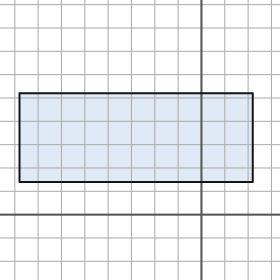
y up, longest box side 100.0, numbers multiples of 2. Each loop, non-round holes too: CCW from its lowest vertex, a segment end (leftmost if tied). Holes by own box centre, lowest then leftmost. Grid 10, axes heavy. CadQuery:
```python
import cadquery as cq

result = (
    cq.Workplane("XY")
    .moveTo(-78.0, 14.0)
    .lineTo(22.0, 14.0)
    .lineTo(22.0, 52.0)
    .lineTo(-78.0, 52.0)
    .close()
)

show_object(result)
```